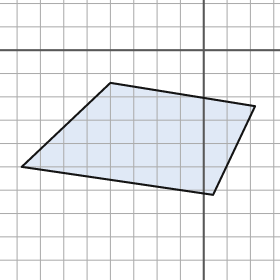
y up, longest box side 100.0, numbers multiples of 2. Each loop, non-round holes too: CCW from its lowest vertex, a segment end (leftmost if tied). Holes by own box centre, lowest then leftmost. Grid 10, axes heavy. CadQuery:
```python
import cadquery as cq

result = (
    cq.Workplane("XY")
    .moveTo(4.0, -62.0)
    .lineTo(22.0, -24.0)
    .lineTo(-40.0, -14.0)
    .lineTo(-78.0, -50.0)
    .close()
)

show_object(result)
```